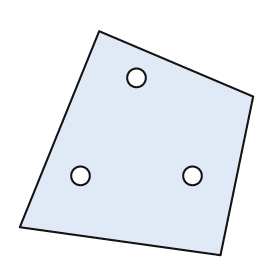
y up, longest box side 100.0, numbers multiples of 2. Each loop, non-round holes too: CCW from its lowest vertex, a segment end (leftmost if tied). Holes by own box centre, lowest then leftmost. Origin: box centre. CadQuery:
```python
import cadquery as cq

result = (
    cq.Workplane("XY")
    .moveTo(36.0, -48.0)
    .lineTo(50.0, 20.0)
    .lineTo(-16.0, 48.0)
    .lineTo(-50.0, -36.0)
    .close()
    .moveTo(-24.0, -14.0)
    .circle(4.0)
    .moveTo(24.0, -14.0)
    .circle(4.0)
    .moveTo(0.0, 28.0)
    .circle(4.0)
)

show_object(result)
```